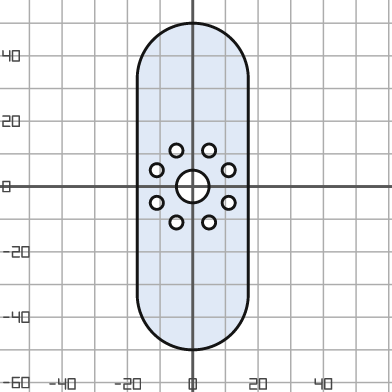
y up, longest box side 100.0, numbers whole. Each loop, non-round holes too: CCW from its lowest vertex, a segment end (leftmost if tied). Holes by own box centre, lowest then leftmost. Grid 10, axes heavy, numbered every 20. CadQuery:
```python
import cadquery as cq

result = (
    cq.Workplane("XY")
    .moveTo(-17.0, -33.0)
    .threePointArc((0.0, -50.0), (17.0, -33.0))
    .lineTo(17.0, 33.0)
    .threePointArc((0.0, 50.0), (-17.0, 33.0))
    .close()
    .moveTo(-5.0, -11.0)
    .circle(2.0)
    .moveTo(5.0, -11.0)
    .circle(2.0)
    .moveTo(-11.0, -5.0)
    .circle(2.0)
    .moveTo(11.0, -5.0)
    .circle(2.0)
    .moveTo(0.0, 0.0)
    .circle(5.0)
    .moveTo(-11.0, 5.0)
    .circle(2.0)
    .moveTo(11.0, 5.0)
    .circle(2.0)
    .moveTo(-5.0, 11.0)
    .circle(2.0)
    .moveTo(5.0, 11.0)
    .circle(2.0)
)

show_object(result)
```